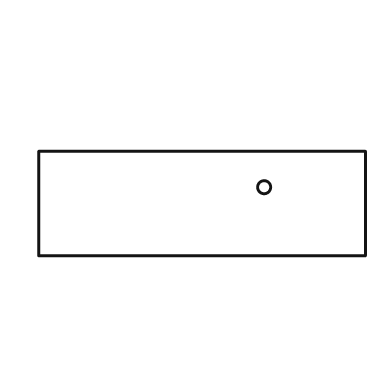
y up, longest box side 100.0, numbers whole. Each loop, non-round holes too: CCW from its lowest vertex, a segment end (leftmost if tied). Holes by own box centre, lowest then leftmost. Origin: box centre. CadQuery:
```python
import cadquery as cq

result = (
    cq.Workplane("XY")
    .moveTo(-50.0, -16.0)
    .lineTo(50.0, -16.0)
    .lineTo(50.0, 16.0)
    .lineTo(-50.0, 16.0)
    .close()
    .moveTo(19.0, 5.0)
    .circle(2.0)
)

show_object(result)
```